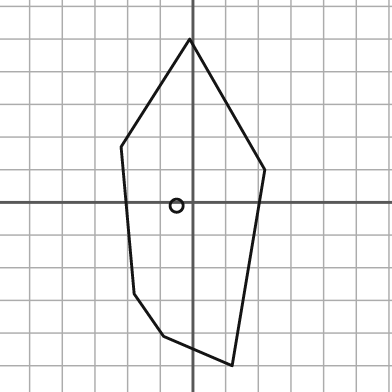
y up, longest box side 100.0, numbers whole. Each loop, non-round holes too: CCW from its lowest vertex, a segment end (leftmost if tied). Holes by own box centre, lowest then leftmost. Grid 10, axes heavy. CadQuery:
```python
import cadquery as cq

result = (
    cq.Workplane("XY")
    .moveTo(12.0, -50.0)
    .lineTo(22.0, 10.0)
    .lineTo(-1.0, 50.0)
    .lineTo(-22.0, 17.0)
    .lineTo(-18.0, -28.0)
    .lineTo(-9.0, -41.0)
    .close()
    .moveTo(-5.0, -1.0)
    .circle(2.0)
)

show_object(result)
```